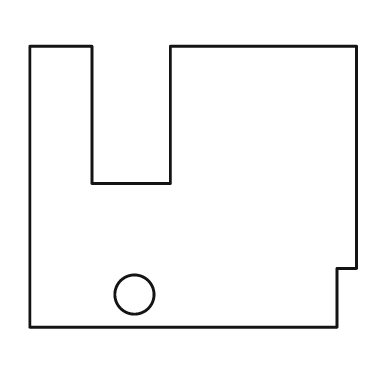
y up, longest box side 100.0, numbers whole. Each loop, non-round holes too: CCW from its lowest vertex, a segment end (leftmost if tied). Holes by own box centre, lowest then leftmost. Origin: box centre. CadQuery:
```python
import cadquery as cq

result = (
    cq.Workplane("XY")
    .moveTo(-50.0, -43.0)
    .lineTo(44.0, -43.0)
    .lineTo(44.0, -25.0)
    .lineTo(50.0, -25.0)
    .lineTo(50.0, 43.0)
    .lineTo(-7.0, 43.0)
    .lineTo(-7.0, 1.0)
    .lineTo(-31.0, 1.0)
    .lineTo(-31.0, 43.0)
    .lineTo(-50.0, 43.0)
    .close()
    .moveTo(-18.0, -33.0)
    .circle(6.0)
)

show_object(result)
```